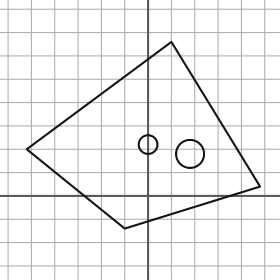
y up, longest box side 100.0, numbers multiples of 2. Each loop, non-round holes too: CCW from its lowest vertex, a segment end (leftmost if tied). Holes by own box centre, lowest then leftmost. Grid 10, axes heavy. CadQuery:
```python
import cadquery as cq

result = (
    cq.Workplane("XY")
    .moveTo(-10.0, -14.0)
    .lineTo(48.0, 4.0)
    .lineTo(10.0, 66.0)
    .lineTo(-52.0, 20.0)
    .close()
    .moveTo(18.0, 18.0)
    .circle(6.0)
    .moveTo(0.0, 22.0)
    .circle(4.0)
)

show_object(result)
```